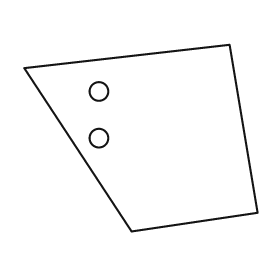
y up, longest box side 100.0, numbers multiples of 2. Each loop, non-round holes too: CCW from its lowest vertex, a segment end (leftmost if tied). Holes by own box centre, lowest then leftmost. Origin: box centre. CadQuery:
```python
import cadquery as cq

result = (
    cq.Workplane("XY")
    .moveTo(-4.0, -40.0)
    .lineTo(50.0, -32.0)
    .lineTo(38.0, 40.0)
    .lineTo(-50.0, 30.0)
    .close()
    .moveTo(-18.0, 0.0)
    .circle(4.0)
    .moveTo(-18.0, 20.0)
    .circle(4.0)
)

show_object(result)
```